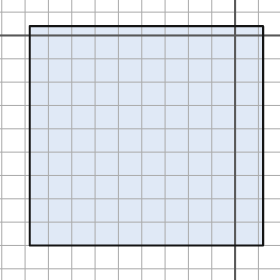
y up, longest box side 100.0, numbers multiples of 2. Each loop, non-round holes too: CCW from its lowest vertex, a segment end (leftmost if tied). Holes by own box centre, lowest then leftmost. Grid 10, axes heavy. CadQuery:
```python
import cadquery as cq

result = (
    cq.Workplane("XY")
    .moveTo(-88.0, -90.0)
    .lineTo(12.0, -90.0)
    .lineTo(12.0, 4.0)
    .lineTo(-88.0, 4.0)
    .close()
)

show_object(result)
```